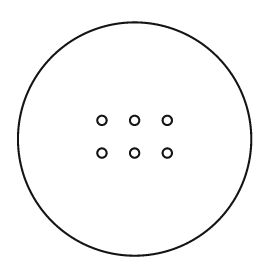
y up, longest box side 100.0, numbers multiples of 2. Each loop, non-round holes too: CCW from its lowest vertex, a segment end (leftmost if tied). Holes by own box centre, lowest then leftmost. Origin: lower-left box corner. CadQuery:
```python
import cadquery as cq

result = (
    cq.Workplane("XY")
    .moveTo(50.0, 50.0)
    .circle(50.0)
    .moveTo(36.0, 44.0)
    .circle(2.0)
    .moveTo(50.0, 44.0)
    .circle(2.0)
    .moveTo(64.0, 44.0)
    .circle(2.0)
    .moveTo(36.0, 58.0)
    .circle(2.0)
    .moveTo(50.0, 58.0)
    .circle(2.0)
    .moveTo(64.0, 58.0)
    .circle(2.0)
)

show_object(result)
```